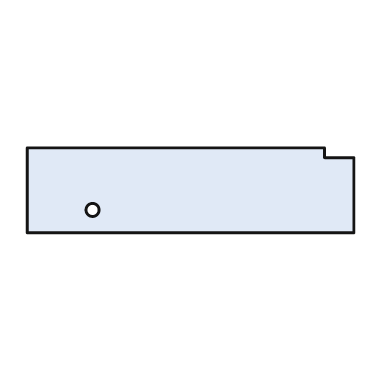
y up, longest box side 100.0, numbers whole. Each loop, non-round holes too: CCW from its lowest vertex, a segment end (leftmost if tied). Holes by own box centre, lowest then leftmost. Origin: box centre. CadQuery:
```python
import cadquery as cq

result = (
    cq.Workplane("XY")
    .moveTo(-50.0, -13.0)
    .lineTo(50.0, -13.0)
    .lineTo(50.0, 10.0)
    .lineTo(41.0, 10.0)
    .lineTo(41.0, 13.0)
    .lineTo(-50.0, 13.0)
    .close()
    .moveTo(-30.0, -6.0)
    .circle(2.0)
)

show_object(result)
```